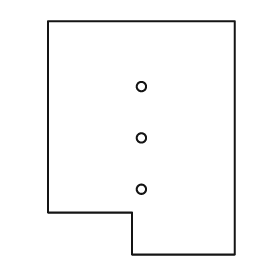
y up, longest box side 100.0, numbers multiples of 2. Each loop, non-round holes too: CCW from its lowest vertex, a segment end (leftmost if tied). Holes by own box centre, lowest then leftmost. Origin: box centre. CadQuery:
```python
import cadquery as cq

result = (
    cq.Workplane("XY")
    .moveTo(-4.0, -50.0)
    .lineTo(40.0, -50.0)
    .lineTo(40.0, 50.0)
    .lineTo(-40.0, 50.0)
    .lineTo(-40.0, -32.0)
    .lineTo(-4.0, -32.0)
    .close()
    .moveTo(0.0, -22.0)
    .circle(2.0)
    .moveTo(0.0, 0.0)
    .circle(2.0)
    .moveTo(0.0, 22.0)
    .circle(2.0)
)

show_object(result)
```